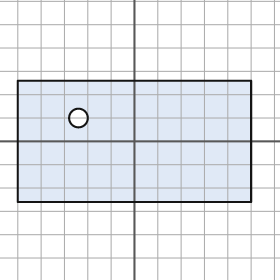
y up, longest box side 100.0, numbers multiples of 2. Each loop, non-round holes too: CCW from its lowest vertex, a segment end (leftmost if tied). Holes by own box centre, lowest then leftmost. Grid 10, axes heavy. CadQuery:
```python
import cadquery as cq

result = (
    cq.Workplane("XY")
    .moveTo(-50.0, -26.0)
    .lineTo(50.0, -26.0)
    .lineTo(50.0, 26.0)
    .lineTo(-50.0, 26.0)
    .close()
    .moveTo(-24.0, 10.0)
    .circle(4.0)
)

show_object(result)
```